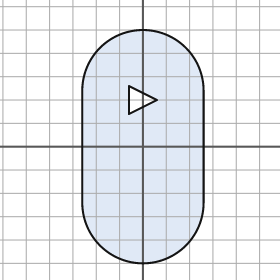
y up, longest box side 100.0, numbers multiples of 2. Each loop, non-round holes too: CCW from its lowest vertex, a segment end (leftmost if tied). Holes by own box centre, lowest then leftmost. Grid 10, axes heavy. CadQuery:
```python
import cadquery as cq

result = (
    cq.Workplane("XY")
    .moveTo(-26.0, -24.0)
    .threePointArc((0.0, -50.0), (26.0, -24.0))
    .lineTo(26.0, 24.0)
    .threePointArc((0.0, 50.0), (-26.0, 24.0))
    .close()
    .moveTo(-6.0, 14.0)
    .lineTo(6.0, 20.0)
    .lineTo(-6.0, 26.0)
    .close()
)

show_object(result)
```